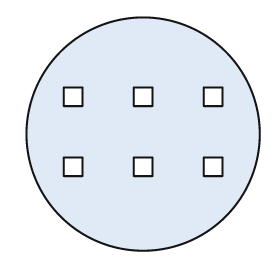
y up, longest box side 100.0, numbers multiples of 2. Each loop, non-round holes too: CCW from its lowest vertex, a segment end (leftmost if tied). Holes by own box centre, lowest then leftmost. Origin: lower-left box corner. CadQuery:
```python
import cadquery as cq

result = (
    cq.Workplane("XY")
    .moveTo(50.0, 50.0)
    .circle(50.0)
    .moveTo(16.0, 32.0)
    .lineTo(24.0, 32.0)
    .lineTo(24.0, 40.0)
    .lineTo(16.0, 40.0)
    .close()
    .moveTo(46.0, 32.0)
    .lineTo(54.0, 32.0)
    .lineTo(54.0, 40.0)
    .lineTo(46.0, 40.0)
    .close()
    .moveTo(76.0, 32.0)
    .lineTo(84.0, 32.0)
    .lineTo(84.0, 40.0)
    .lineTo(76.0, 40.0)
    .close()
    .moveTo(16.0, 62.0)
    .lineTo(24.0, 62.0)
    .lineTo(24.0, 70.0)
    .lineTo(16.0, 70.0)
    .close()
    .moveTo(46.0, 62.0)
    .lineTo(54.0, 62.0)
    .lineTo(54.0, 70.0)
    .lineTo(46.0, 70.0)
    .close()
    .moveTo(76.0, 62.0)
    .lineTo(84.0, 62.0)
    .lineTo(84.0, 70.0)
    .lineTo(76.0, 70.0)
    .close()
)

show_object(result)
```